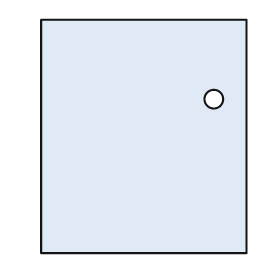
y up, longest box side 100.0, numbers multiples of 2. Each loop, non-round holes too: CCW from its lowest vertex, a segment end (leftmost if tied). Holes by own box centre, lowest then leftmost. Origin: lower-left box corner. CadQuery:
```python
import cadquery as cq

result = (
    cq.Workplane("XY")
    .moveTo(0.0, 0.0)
    .lineTo(88.0, 0.0)
    .lineTo(88.0, 100.0)
    .lineTo(0.0, 100.0)
    .close()
    .moveTo(74.0, 66.0)
    .circle(4.0)
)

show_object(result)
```